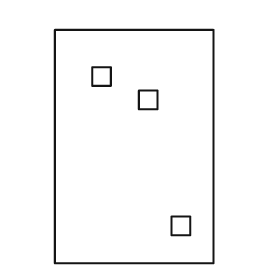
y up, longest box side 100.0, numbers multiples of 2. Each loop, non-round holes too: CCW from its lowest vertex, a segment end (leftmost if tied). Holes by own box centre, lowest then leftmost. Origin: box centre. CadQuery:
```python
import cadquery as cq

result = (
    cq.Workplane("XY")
    .moveTo(-34.0, -50.0)
    .lineTo(34.0, -50.0)
    .lineTo(34.0, 50.0)
    .lineTo(-34.0, 50.0)
    .close()
    .moveTo(16.0, -38.0)
    .lineTo(24.0, -38.0)
    .lineTo(24.0, -30.0)
    .lineTo(16.0, -30.0)
    .close()
    .moveTo(2.0, 16.0)
    .lineTo(10.0, 16.0)
    .lineTo(10.0, 24.0)
    .lineTo(2.0, 24.0)
    .close()
    .moveTo(-18.0, 26.0)
    .lineTo(-10.0, 26.0)
    .lineTo(-10.0, 34.0)
    .lineTo(-18.0, 34.0)
    .close()
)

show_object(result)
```